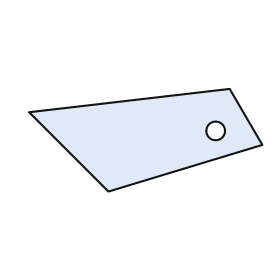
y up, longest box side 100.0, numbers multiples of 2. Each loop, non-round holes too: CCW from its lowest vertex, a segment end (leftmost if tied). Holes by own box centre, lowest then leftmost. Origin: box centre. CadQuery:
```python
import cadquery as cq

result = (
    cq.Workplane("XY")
    .moveTo(-16.0, -22.0)
    .lineTo(50.0, -2.0)
    .lineTo(36.0, 22.0)
    .lineTo(-50.0, 12.0)
    .close()
    .moveTo(30.0, 4.0)
    .circle(4.0)
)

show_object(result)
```